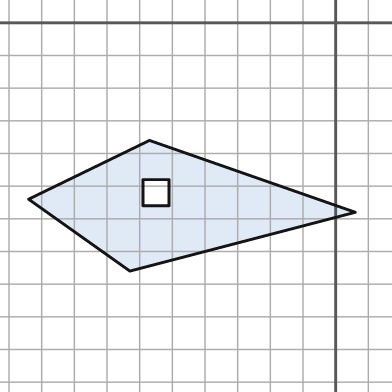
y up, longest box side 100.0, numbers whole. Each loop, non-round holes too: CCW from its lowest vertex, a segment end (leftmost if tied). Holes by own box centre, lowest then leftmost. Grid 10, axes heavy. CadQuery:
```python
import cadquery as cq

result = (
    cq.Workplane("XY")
    .moveTo(-63.0, -76.0)
    .lineTo(6.0, -58.0)
    .lineTo(-57.0, -36.0)
    .lineTo(-94.0, -54.0)
    .close()
    .moveTo(-59.0, -56.0)
    .lineTo(-51.0, -56.0)
    .lineTo(-51.0, -48.0)
    .lineTo(-59.0, -48.0)
    .close()
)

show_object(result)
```